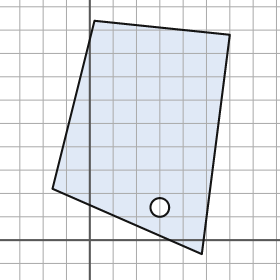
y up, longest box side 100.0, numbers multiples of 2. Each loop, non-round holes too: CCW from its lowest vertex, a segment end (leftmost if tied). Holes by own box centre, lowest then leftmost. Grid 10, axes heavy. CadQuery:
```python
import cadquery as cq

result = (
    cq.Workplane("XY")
    .moveTo(48.0, -6.0)
    .lineTo(60.0, 88.0)
    .lineTo(2.0, 94.0)
    .lineTo(-16.0, 22.0)
    .close()
    .moveTo(30.0, 14.0)
    .circle(4.0)
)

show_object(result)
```